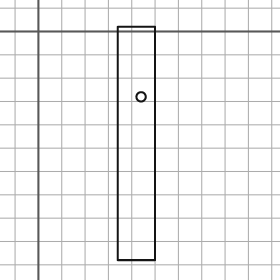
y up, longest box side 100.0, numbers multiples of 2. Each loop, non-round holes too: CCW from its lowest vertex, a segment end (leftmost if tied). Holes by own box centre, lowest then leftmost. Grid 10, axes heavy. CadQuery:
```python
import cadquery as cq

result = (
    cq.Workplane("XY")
    .moveTo(34.0, -98.0)
    .lineTo(50.0, -98.0)
    .lineTo(50.0, 2.0)
    .lineTo(34.0, 2.0)
    .close()
    .moveTo(44.0, -28.0)
    .circle(2.0)
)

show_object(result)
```